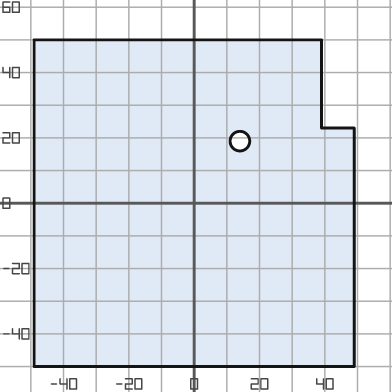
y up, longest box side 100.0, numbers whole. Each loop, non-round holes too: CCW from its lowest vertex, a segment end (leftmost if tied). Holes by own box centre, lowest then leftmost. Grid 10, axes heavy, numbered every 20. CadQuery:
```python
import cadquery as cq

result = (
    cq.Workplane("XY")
    .moveTo(-49.0, -50.0)
    .lineTo(49.0, -50.0)
    .lineTo(49.0, 23.0)
    .lineTo(39.0, 23.0)
    .lineTo(39.0, 50.0)
    .lineTo(-49.0, 50.0)
    .close()
    .moveTo(14.0, 19.0)
    .circle(3.0)
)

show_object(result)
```